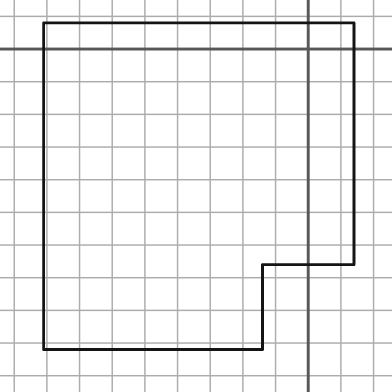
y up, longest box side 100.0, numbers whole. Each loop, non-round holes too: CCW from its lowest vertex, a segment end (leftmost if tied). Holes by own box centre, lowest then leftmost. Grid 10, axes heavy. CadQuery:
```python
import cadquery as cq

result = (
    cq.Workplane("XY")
    .moveTo(-81.0, -92.0)
    .lineTo(-14.0, -92.0)
    .lineTo(-14.0, -66.0)
    .lineTo(14.0, -66.0)
    .lineTo(14.0, 8.0)
    .lineTo(-81.0, 8.0)
    .close()
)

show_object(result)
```